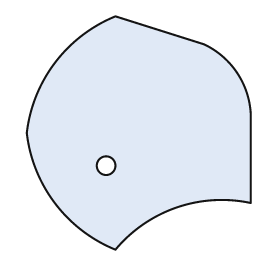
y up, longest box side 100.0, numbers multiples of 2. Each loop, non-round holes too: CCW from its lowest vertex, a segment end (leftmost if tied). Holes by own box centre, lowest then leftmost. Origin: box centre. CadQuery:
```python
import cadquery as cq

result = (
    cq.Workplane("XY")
    .moveTo(-10.0, -50.0)
    .threePointArc((16.0, -32.0), (48.0, -30.0))
    .lineTo(48.0, 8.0)
    .threePointArc((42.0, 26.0), (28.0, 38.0))
    .lineTo(-10.0, 50.0)
    .threePointArc((-36.0, 30.0), (-48.0, 0.0))
    .threePointArc((-36.0, -30.0), (-10.0, -50.0))
    .close()
    .moveTo(-14.0, -14.0)
    .circle(4.0)
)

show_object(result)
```